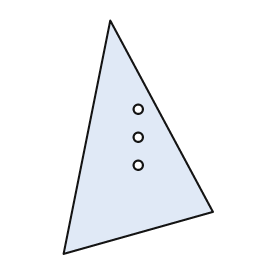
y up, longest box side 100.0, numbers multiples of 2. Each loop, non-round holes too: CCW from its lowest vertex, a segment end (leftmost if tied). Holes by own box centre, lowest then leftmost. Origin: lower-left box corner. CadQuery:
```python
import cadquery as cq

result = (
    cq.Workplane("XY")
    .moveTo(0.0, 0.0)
    .lineTo(64.0, 18.0)
    .lineTo(20.0, 100.0)
    .close()
    .moveTo(32.0, 38.0)
    .circle(2.0)
    .moveTo(32.0, 50.0)
    .circle(2.0)
    .moveTo(32.0, 62.0)
    .circle(2.0)
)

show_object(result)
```